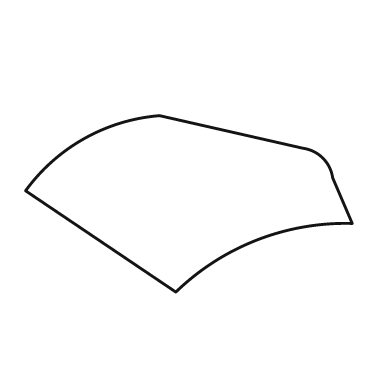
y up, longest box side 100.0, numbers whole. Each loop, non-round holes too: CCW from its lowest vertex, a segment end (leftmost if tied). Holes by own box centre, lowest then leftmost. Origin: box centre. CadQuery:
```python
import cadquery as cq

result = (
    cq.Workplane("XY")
    .moveTo(-4.0, -27.0)
    .threePointArc((21.0, -11.0), (50.0, -6.0))
    .lineTo(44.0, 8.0)
    .threePointArc((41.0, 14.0), (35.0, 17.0))
    .lineTo(-9.0, 27.0)
    .threePointArc((-32.0, 20.0), (-50.0, 4.0))
    .close()
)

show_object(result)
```